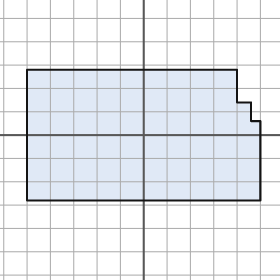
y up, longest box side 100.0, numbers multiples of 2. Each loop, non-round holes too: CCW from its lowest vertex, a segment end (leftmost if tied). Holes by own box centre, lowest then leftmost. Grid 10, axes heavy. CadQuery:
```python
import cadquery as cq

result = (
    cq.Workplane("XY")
    .moveTo(-50.0, -28.0)
    .lineTo(50.0, -28.0)
    .lineTo(50.0, 6.0)
    .lineTo(46.0, 6.0)
    .lineTo(46.0, 14.0)
    .lineTo(40.0, 14.0)
    .lineTo(40.0, 28.0)
    .lineTo(-50.0, 28.0)
    .close()
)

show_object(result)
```